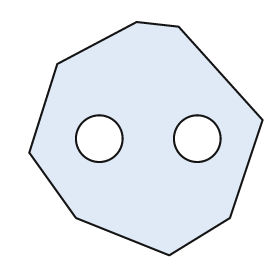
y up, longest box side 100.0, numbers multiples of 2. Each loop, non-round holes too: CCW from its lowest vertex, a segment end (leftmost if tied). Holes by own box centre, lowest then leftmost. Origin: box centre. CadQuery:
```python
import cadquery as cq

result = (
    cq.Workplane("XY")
    .moveTo(10.0, -50.0)
    .lineTo(36.0, -34.0)
    .lineTo(50.0, 8.0)
    .lineTo(14.0, 48.0)
    .lineTo(-4.0, 50.0)
    .lineTo(-38.0, 32.0)
    .lineTo(-50.0, -6.0)
    .lineTo(-30.0, -34.0)
    .close()
    .moveTo(-20.0, 0.0)
    .circle(10.0)
    .moveTo(22.0, 0.0)
    .circle(10.0)
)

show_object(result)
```